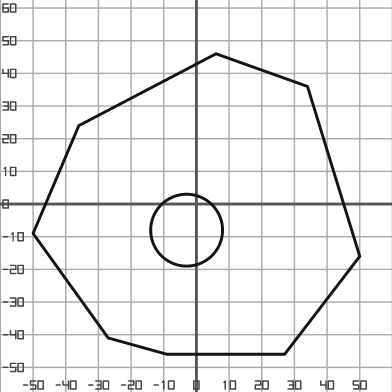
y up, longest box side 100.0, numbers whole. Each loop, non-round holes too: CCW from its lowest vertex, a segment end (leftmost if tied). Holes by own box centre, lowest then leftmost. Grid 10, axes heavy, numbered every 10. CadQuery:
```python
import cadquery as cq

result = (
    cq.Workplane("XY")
    .moveTo(-9.0, -46.0)
    .lineTo(27.0, -46.0)
    .lineTo(50.0, -16.0)
    .lineTo(34.0, 36.0)
    .lineTo(6.0, 46.0)
    .lineTo(-36.0, 24.0)
    .lineTo(-50.0, -9.0)
    .lineTo(-27.0, -41.0)
    .close()
    .moveTo(-3.0, -8.0)
    .circle(11.0)
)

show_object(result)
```